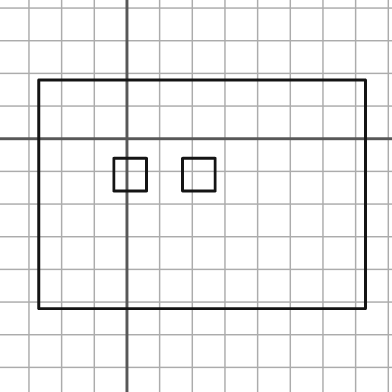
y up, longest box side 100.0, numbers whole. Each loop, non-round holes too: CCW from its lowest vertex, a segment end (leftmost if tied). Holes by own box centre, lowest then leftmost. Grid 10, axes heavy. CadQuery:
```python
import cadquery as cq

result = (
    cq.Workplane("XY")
    .moveTo(-27.0, -52.0)
    .lineTo(73.0, -52.0)
    .lineTo(73.0, 18.0)
    .lineTo(-27.0, 18.0)
    .close()
    .moveTo(-4.0, -16.0)
    .lineTo(6.0, -16.0)
    .lineTo(6.0, -6.0)
    .lineTo(-4.0, -6.0)
    .close()
    .moveTo(17.0, -16.0)
    .lineTo(27.0, -16.0)
    .lineTo(27.0, -6.0)
    .lineTo(17.0, -6.0)
    .close()
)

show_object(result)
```